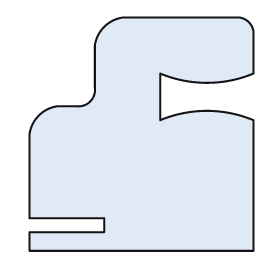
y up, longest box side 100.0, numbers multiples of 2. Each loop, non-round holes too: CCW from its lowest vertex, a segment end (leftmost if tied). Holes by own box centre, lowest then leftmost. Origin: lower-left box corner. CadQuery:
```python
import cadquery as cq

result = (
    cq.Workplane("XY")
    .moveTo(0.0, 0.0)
    .lineTo(96.0, 0.0)
    .lineTo(96.0, 56.0)
    .threePointArc((76.0, 60.0), (56.0, 56.0))
    .lineTo(56.0, 76.0)
    .threePointArc((76.0, 72.0), (96.0, 76.0))
    .lineTo(96.0, 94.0)
    .threePointArc((94.0, 98.0), (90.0, 100.0))
    .lineTo(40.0, 100.0)
    .threePointArc((32.0, 96.0), (28.0, 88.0))
    .lineTo(28.0, 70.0)
    .threePointArc((26.0, 64.0), (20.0, 62.0))
    .lineTo(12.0, 62.0)
    .threePointArc((4.0, 58.0), (0.0, 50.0))
    .lineTo(0.0, 14.0)
    .lineTo(32.0, 14.0)
    .lineTo(32.0, 8.0)
    .lineTo(0.0, 8.0)
    .close()
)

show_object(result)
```